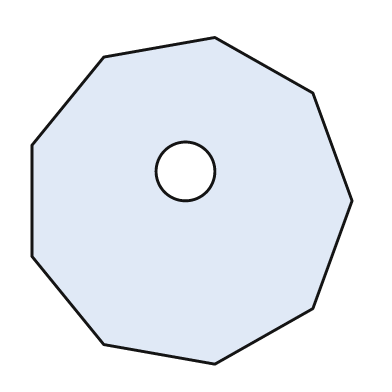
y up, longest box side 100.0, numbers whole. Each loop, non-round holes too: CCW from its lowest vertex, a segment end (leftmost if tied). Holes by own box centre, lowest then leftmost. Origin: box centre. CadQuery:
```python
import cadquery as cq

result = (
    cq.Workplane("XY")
    .moveTo(7.0, -50.0)
    .lineTo(37.0, -33.0)
    .lineTo(49.0, 0.0)
    .lineTo(37.0, 33.0)
    .lineTo(7.0, 50.0)
    .lineTo(-27.0, 44.0)
    .lineTo(-49.0, 17.0)
    .lineTo(-49.0, -17.0)
    .lineTo(-27.0, -44.0)
    .close()
    .moveTo(-2.0, 9.0)
    .circle(9.0)
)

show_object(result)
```